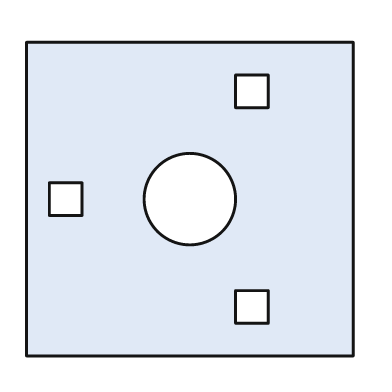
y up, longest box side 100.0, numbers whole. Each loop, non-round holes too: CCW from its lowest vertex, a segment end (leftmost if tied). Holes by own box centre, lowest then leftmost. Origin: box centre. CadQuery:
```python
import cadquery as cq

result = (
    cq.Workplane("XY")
    .moveTo(-50.0, -48.0)
    .lineTo(50.0, -48.0)
    .lineTo(50.0, 48.0)
    .lineTo(-50.0, 48.0)
    .close()
    .moveTo(14.0, -38.0)
    .lineTo(24.0, -38.0)
    .lineTo(24.0, -28.0)
    .lineTo(14.0, -28.0)
    .close()
    .moveTo(-43.0, -5.0)
    .lineTo(-33.0, -5.0)
    .lineTo(-33.0, 5.0)
    .lineTo(-43.0, 5.0)
    .close()
    .moveTo(0.0, 0.0)
    .circle(14.0)
    .moveTo(14.0, 28.0)
    .lineTo(24.0, 28.0)
    .lineTo(24.0, 38.0)
    .lineTo(14.0, 38.0)
    .close()
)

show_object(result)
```